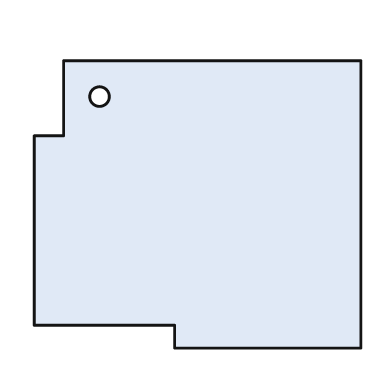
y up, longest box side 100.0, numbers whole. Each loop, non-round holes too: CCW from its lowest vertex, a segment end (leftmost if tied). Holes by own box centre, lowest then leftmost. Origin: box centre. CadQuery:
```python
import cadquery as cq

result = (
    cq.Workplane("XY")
    .moveTo(-7.0, -44.0)
    .lineTo(50.0, -44.0)
    .lineTo(50.0, 44.0)
    .lineTo(-41.0, 44.0)
    .lineTo(-41.0, 21.0)
    .lineTo(-50.0, 21.0)
    .lineTo(-50.0, -37.0)
    .lineTo(-7.0, -37.0)
    .close()
    .moveTo(-30.0, 33.0)
    .circle(3.0)
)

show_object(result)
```